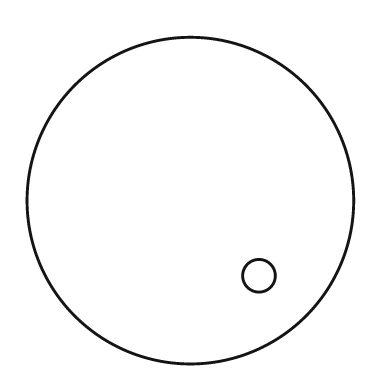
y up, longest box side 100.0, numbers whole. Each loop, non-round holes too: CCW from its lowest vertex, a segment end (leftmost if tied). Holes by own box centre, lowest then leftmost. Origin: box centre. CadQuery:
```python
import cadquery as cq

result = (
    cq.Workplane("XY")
    .moveTo(0.0, 0.0)
    .circle(50.0)
    .moveTo(21.0, -23.0)
    .circle(5.0)
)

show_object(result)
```